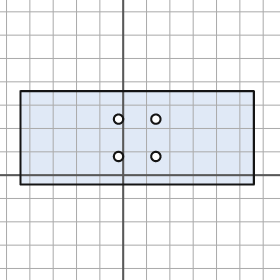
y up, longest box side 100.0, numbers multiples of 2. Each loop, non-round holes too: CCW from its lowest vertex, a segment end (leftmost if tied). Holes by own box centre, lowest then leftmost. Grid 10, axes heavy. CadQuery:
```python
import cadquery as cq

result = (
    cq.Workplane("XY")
    .moveTo(-44.0, -4.0)
    .lineTo(56.0, -4.0)
    .lineTo(56.0, 36.0)
    .lineTo(-44.0, 36.0)
    .close()
    .moveTo(-2.0, 8.0)
    .circle(2.0)
    .moveTo(14.0, 8.0)
    .circle(2.0)
    .moveTo(-2.0, 24.0)
    .circle(2.0)
    .moveTo(14.0, 24.0)
    .circle(2.0)
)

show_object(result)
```